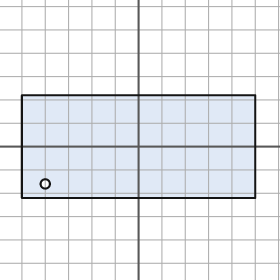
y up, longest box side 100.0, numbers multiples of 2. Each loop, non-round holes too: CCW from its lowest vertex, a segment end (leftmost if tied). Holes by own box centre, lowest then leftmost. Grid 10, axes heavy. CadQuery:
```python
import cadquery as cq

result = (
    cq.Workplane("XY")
    .moveTo(-50.0, -22.0)
    .lineTo(50.0, -22.0)
    .lineTo(50.0, 22.0)
    .lineTo(-50.0, 22.0)
    .close()
    .moveTo(-40.0, -16.0)
    .circle(2.0)
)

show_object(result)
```